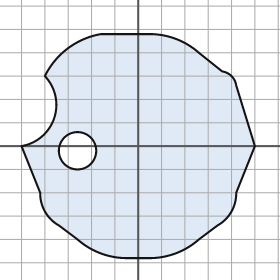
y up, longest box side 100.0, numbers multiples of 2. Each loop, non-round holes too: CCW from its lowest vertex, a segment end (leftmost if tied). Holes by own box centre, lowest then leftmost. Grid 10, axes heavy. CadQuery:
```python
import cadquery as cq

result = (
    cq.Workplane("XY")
    .moveTo(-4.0, -48.0)
    .lineTo(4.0, -48.0)
    .threePointArc((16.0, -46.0), (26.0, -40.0))
    .lineTo(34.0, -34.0)
    .threePointArc((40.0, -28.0), (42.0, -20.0))
    .lineTo(50.0, 0.0)
    .lineTo(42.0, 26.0)
    .threePointArc((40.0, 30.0), (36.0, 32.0))
    .lineTo(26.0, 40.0)
    .threePointArc((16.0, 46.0), (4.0, 48.0))
    .lineTo(-16.0, 48.0)
    .threePointArc((-30.0, 42.0), (-40.0, 30.0))
    .threePointArc((-36.0, 12.0), (-50.0, 0.0))
    .lineTo(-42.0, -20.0)
    .threePointArc((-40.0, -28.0), (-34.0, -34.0))
    .lineTo(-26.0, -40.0)
    .threePointArc((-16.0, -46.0), (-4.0, -48.0))
    .close()
    .moveTo(-26.0, -2.0)
    .circle(8.0)
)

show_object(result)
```